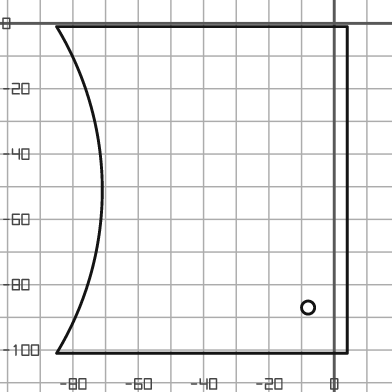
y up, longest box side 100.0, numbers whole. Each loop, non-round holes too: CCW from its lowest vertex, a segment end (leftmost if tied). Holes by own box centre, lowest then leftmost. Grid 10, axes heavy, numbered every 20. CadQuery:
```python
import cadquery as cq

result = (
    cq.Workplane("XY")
    .moveTo(-85.0, -101.0)
    .lineTo(4.0, -101.0)
    .lineTo(4.0, -1.0)
    .lineTo(-85.0, -1.0)
    .threePointArc((-71.0, -51.0), (-85.0, -101.0))
    .close()
    .moveTo(-8.0, -87.0)
    .circle(2.0)
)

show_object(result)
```